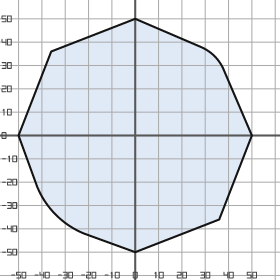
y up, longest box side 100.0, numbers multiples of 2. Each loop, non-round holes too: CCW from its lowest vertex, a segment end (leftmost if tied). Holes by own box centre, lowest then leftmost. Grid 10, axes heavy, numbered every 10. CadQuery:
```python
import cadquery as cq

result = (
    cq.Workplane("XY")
    .moveTo(0.0, -50.0)
    .lineTo(36.0, -36.0)
    .lineTo(50.0, 0.0)
    .lineTo(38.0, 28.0)
    .threePointArc((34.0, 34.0), (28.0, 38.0))
    .lineTo(0.0, 50.0)
    .lineTo(-36.0, 36.0)
    .lineTo(-50.0, 0.0)
    .lineTo(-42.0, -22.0)
    .threePointArc((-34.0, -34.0), (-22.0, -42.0))
    .close()
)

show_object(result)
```